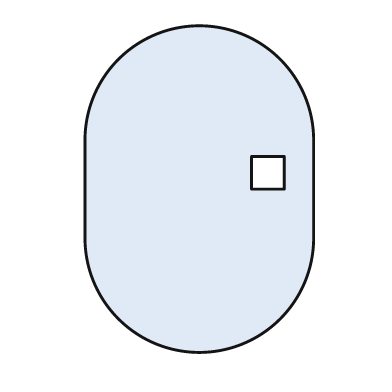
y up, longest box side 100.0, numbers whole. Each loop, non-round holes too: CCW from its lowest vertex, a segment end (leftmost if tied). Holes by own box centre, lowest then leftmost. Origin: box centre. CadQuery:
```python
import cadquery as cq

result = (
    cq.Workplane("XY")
    .moveTo(-35.0, -15.0)
    .threePointArc((0.0, -50.0), (35.0, -15.0))
    .lineTo(35.0, 15.0)
    .threePointArc((0.0, 50.0), (-35.0, 15.0))
    .close()
    .moveTo(16.0, 0.0)
    .lineTo(26.0, 0.0)
    .lineTo(26.0, 10.0)
    .lineTo(16.0, 10.0)
    .close()
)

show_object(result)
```